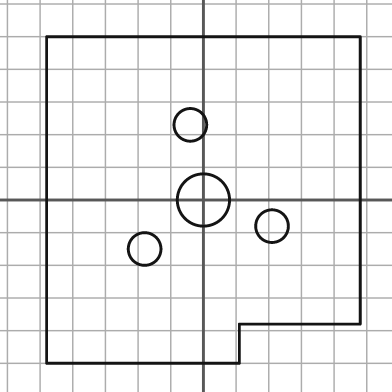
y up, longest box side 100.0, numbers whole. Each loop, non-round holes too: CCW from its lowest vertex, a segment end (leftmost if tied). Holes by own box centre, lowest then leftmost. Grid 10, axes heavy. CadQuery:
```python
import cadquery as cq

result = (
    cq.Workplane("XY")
    .moveTo(-48.0, -50.0)
    .lineTo(11.0, -50.0)
    .lineTo(11.0, -38.0)
    .lineTo(48.0, -38.0)
    .lineTo(48.0, 50.0)
    .lineTo(-48.0, 50.0)
    .close()
    .moveTo(-18.0, -15.0)
    .circle(5.0)
    .moveTo(21.0, -8.0)
    .circle(5.0)
    .moveTo(0.0, 0.0)
    .circle(8.0)
    .moveTo(-4.0, 23.0)
    .circle(5.0)
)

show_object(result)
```